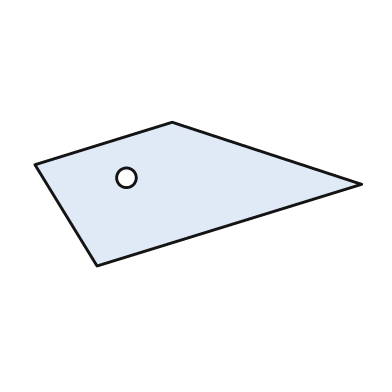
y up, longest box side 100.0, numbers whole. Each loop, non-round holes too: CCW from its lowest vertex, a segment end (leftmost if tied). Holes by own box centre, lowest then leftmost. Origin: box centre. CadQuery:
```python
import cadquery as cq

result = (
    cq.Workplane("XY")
    .moveTo(-31.0, -22.0)
    .lineTo(50.0, 3.0)
    .lineTo(-8.0, 22.0)
    .lineTo(-50.0, 9.0)
    .close()
    .moveTo(-22.0, 5.0)
    .circle(3.0)
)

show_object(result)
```